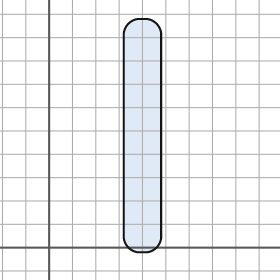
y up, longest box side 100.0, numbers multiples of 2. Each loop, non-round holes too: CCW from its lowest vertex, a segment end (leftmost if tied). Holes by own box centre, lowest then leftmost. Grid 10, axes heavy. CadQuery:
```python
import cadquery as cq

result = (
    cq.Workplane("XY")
    .moveTo(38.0, -2.0)
    .lineTo(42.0, -2.0)
    .threePointArc((46.0, 0.0), (48.0, 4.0))
    .lineTo(48.0, 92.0)
    .threePointArc((46.0, 96.0), (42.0, 98.0))
    .lineTo(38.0, 98.0)
    .threePointArc((34.0, 96.0), (32.0, 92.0))
    .lineTo(32.0, 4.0)
    .threePointArc((34.0, 0.0), (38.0, -2.0))
    .close()
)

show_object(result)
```